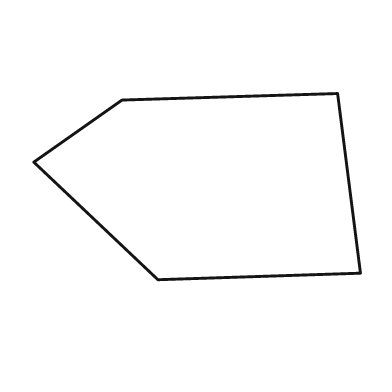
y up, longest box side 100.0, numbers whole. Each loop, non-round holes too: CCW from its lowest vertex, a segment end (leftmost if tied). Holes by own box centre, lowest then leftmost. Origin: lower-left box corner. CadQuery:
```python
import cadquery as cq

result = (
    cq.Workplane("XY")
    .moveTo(38.0, 0.0)
    .lineTo(100.0, 2.0)
    .lineTo(93.0, 57.0)
    .lineTo(27.0, 55.0)
    .lineTo(0.0, 36.0)
    .close()
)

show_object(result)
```